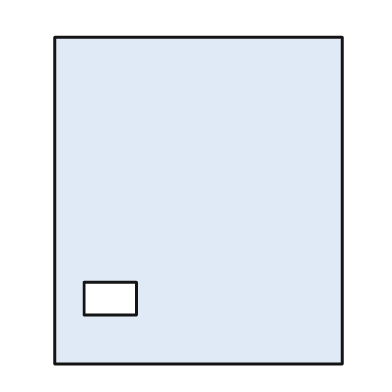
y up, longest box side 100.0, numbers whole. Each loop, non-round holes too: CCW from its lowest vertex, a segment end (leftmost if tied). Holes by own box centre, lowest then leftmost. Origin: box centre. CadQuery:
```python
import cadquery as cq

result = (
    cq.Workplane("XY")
    .moveTo(-44.0, -50.0)
    .lineTo(44.0, -50.0)
    .lineTo(44.0, 50.0)
    .lineTo(-44.0, 50.0)
    .close()
    .moveTo(-35.0, -35.0)
    .lineTo(-19.0, -35.0)
    .lineTo(-19.0, -25.0)
    .lineTo(-35.0, -25.0)
    .close()
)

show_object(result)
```